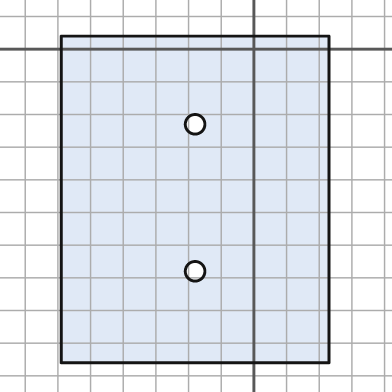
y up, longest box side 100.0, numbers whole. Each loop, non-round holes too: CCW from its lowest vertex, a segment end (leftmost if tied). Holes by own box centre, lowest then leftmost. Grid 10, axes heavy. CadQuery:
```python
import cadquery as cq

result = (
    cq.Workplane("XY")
    .moveTo(-59.0, -96.0)
    .lineTo(23.0, -96.0)
    .lineTo(23.0, 4.0)
    .lineTo(-59.0, 4.0)
    .close()
    .moveTo(-18.0, -68.0)
    .circle(3.0)
    .moveTo(-18.0, -23.0)
    .circle(3.0)
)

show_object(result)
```